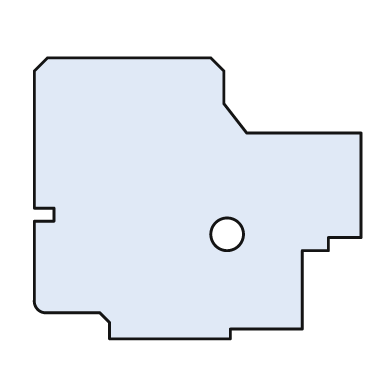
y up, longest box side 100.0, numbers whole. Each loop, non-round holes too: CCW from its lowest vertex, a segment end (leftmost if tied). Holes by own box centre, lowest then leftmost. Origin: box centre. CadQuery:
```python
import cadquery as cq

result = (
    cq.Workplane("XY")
    .moveTo(-27.0, -43.0)
    .lineTo(10.0, -43.0)
    .lineTo(10.0, -40.0)
    .lineTo(32.0, -40.0)
    .lineTo(32.0, -16.0)
    .lineTo(40.0, -16.0)
    .lineTo(40.0, -12.0)
    .lineTo(50.0, -12.0)
    .lineTo(50.0, 20.0)
    .lineTo(15.0, 20.0)
    .lineTo(8.0, 29.0)
    .lineTo(8.0, 39.0)
    .lineTo(4.0, 43.0)
    .lineTo(-46.0, 43.0)
    .lineTo(-50.0, 39.0)
    .lineTo(-50.0, -3.0)
    .lineTo(-44.0, -3.0)
    .lineTo(-44.0, -7.0)
    .lineTo(-50.0, -7.0)
    .lineTo(-50.0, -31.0)
    .threePointArc((-49.0, -34.0), (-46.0, -35.0))
    .lineTo(-30.0, -35.0)
    .lineTo(-27.0, -38.0)
    .close()
    .moveTo(9.0, -11.0)
    .circle(5.0)
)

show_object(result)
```